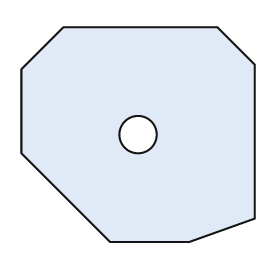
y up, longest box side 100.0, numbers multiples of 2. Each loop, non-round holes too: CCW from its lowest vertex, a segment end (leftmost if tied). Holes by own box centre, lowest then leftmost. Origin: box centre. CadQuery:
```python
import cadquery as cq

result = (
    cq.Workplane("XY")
    .moveTo(-12.0, -46.0)
    .lineTo(22.0, -46.0)
    .lineTo(50.0, -36.0)
    .lineTo(50.0, 30.0)
    .lineTo(34.0, 46.0)
    .lineTo(-32.0, 46.0)
    .lineTo(-50.0, 28.0)
    .lineTo(-50.0, -8.0)
    .close()
    .moveTo(0.0, 0.0)
    .circle(8.0)
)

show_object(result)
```